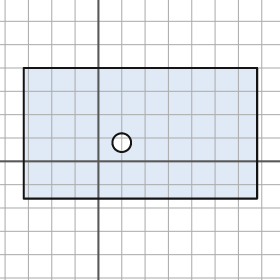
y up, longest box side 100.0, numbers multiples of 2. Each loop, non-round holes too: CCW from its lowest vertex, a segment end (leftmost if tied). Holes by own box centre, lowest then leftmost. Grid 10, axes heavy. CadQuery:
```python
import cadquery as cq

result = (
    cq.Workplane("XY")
    .moveTo(-32.0, -16.0)
    .lineTo(68.0, -16.0)
    .lineTo(68.0, 40.0)
    .lineTo(-32.0, 40.0)
    .close()
    .moveTo(10.0, 8.0)
    .circle(4.0)
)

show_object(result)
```